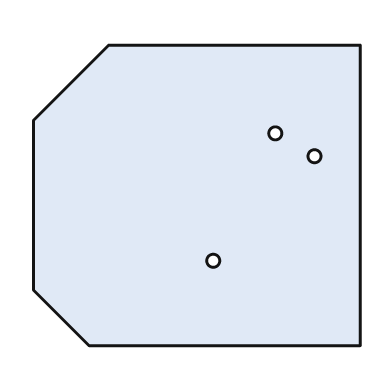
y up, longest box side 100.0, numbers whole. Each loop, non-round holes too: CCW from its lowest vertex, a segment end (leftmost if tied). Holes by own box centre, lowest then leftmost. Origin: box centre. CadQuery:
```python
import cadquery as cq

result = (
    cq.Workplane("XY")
    .moveTo(-33.0, -46.0)
    .lineTo(50.0, -46.0)
    .lineTo(50.0, 46.0)
    .lineTo(-27.0, 46.0)
    .lineTo(-50.0, 23.0)
    .lineTo(-50.0, -29.0)
    .close()
    .moveTo(5.0, -20.0)
    .circle(2.0)
    .moveTo(36.0, 12.0)
    .circle(2.0)
    .moveTo(24.0, 19.0)
    .circle(2.0)
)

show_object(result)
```